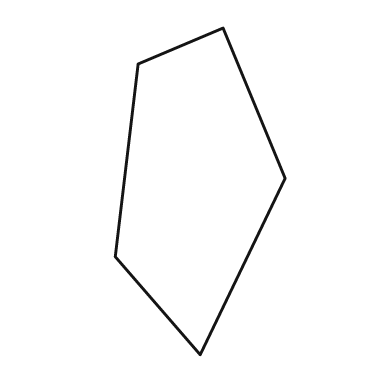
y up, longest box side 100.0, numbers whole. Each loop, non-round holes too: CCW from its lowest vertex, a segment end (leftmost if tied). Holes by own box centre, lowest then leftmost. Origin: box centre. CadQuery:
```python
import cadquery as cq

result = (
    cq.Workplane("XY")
    .moveTo(0.0, -50.0)
    .lineTo(26.0, 4.0)
    .lineTo(7.0, 50.0)
    .lineTo(-19.0, 39.0)
    .lineTo(-26.0, -20.0)
    .close()
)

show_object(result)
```